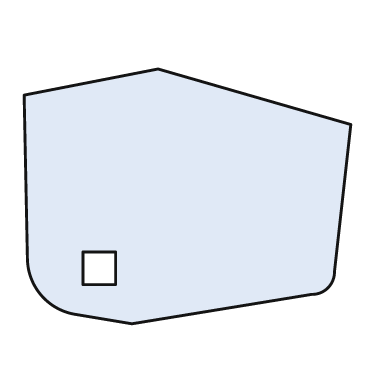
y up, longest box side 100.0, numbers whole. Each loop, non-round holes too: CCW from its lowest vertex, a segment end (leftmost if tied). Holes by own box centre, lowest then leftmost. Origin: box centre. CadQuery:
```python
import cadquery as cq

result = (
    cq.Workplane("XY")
    .moveTo(-17.0, -39.0)
    .lineTo(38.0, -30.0)
    .threePointArc((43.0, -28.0), (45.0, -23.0))
    .lineTo(50.0, 22.0)
    .lineTo(-9.0, 39.0)
    .lineTo(-50.0, 31.0)
    .lineTo(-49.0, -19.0)
    .threePointArc((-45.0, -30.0), (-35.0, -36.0))
    .close()
    .moveTo(-32.0, -27.0)
    .lineTo(-22.0, -27.0)
    .lineTo(-22.0, -17.0)
    .lineTo(-32.0, -17.0)
    .close()
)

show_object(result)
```